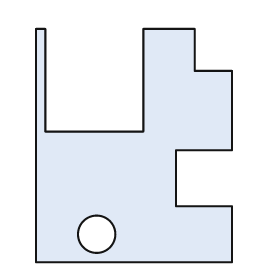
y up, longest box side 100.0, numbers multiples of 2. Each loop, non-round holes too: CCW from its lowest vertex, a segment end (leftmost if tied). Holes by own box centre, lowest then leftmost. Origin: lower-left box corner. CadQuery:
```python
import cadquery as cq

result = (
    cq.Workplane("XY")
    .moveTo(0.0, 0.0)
    .lineTo(84.0, 0.0)
    .lineTo(84.0, 24.0)
    .lineTo(60.0, 24.0)
    .lineTo(60.0, 48.0)
    .lineTo(84.0, 48.0)
    .lineTo(84.0, 82.0)
    .lineTo(68.0, 82.0)
    .lineTo(68.0, 100.0)
    .lineTo(46.0, 100.0)
    .lineTo(46.0, 56.0)
    .lineTo(4.0, 56.0)
    .lineTo(4.0, 100.0)
    .lineTo(0.0, 100.0)
    .close()
    .moveTo(26.0, 12.0)
    .circle(8.0)
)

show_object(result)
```